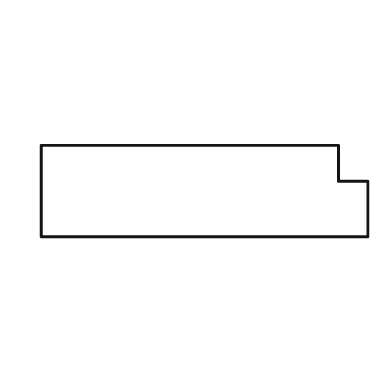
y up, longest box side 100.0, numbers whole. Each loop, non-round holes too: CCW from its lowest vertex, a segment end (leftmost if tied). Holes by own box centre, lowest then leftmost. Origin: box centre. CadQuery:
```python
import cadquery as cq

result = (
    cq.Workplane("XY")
    .moveTo(-50.0, -14.0)
    .lineTo(50.0, -14.0)
    .lineTo(50.0, 3.0)
    .lineTo(41.0, 3.0)
    .lineTo(41.0, 14.0)
    .lineTo(-50.0, 14.0)
    .close()
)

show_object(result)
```